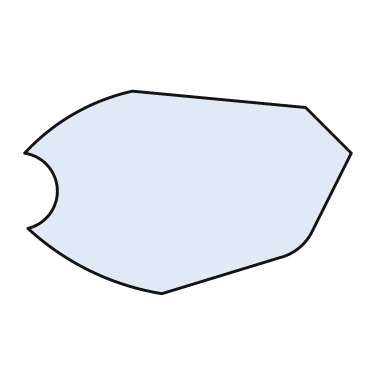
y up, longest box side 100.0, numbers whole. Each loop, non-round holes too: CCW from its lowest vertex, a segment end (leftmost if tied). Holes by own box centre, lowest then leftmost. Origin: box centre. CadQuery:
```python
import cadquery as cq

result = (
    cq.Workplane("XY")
    .moveTo(-8.0, -31.0)
    .lineTo(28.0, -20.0)
    .threePointArc((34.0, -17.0), (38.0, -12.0))
    .lineTo(50.0, 12.0)
    .lineTo(36.0, 26.0)
    .lineTo(-17.0, 31.0)
    .threePointArc((-35.0, 24.0), (-50.0, 12.0))
    .threePointArc((-40.0, 1.0), (-49.0, -11.0))
    .threePointArc((-30.0, -24.0), (-8.0, -31.0))
    .close()
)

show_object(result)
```